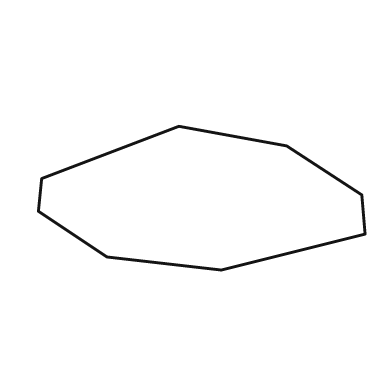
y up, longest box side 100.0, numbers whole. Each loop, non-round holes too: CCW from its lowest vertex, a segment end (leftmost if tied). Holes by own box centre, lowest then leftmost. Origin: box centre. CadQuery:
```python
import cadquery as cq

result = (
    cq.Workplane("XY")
    .moveTo(6.0, -22.0)
    .lineTo(50.0, -11.0)
    .lineTo(49.0, 1.0)
    .lineTo(26.0, 16.0)
    .lineTo(-7.0, 22.0)
    .lineTo(-49.0, 6.0)
    .lineTo(-50.0, -4.0)
    .lineTo(-29.0, -18.0)
    .close()
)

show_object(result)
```